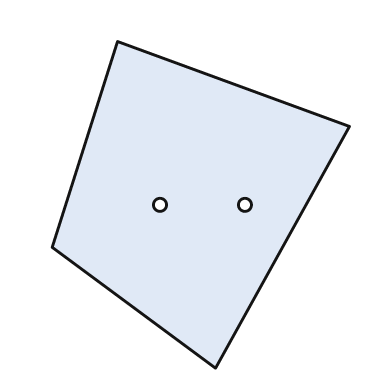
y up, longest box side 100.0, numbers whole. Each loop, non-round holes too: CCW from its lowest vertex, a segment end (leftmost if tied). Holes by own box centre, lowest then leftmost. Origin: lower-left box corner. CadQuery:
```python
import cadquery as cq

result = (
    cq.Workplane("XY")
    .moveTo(50.0, 0.0)
    .lineTo(91.0, 74.0)
    .lineTo(20.0, 100.0)
    .lineTo(0.0, 37.0)
    .close()
    .moveTo(33.0, 50.0)
    .circle(2.0)
    .moveTo(59.0, 50.0)
    .circle(2.0)
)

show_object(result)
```